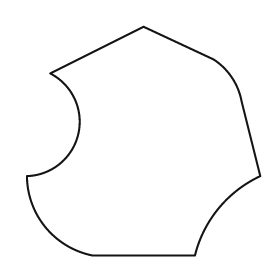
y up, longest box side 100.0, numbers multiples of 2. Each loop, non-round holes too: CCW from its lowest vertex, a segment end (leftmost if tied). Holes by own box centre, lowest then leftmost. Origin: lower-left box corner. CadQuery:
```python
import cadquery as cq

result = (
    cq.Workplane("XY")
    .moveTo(28.0, 0.0)
    .lineTo(72.0, 0.0)
    .threePointArc((82.0, 20.0), (100.0, 34.0))
    .lineTo(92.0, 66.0)
    .threePointArc((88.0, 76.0), (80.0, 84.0))
    .lineTo(50.0, 98.0)
    .lineTo(10.0, 78.0)
    .threePointArc((22.0, 52.0), (0.0, 34.0))
    .threePointArc((8.0, 12.0), (28.0, 0.0))
    .close()
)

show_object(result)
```